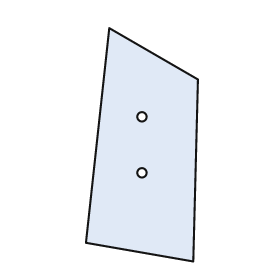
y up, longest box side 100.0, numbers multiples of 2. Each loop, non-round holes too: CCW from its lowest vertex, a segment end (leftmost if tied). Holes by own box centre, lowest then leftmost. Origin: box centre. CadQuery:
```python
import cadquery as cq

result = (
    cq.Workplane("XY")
    .moveTo(22.0, -50.0)
    .lineTo(24.0, 28.0)
    .lineTo(-14.0, 50.0)
    .lineTo(-24.0, -42.0)
    .close()
    .moveTo(0.0, -12.0)
    .circle(2.0)
    .moveTo(0.0, 12.0)
    .circle(2.0)
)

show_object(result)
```